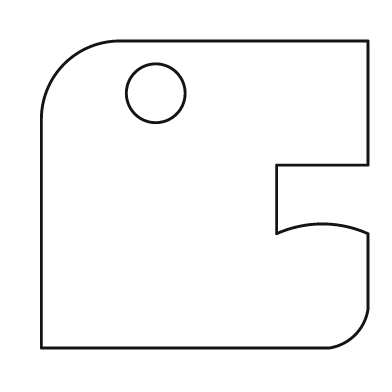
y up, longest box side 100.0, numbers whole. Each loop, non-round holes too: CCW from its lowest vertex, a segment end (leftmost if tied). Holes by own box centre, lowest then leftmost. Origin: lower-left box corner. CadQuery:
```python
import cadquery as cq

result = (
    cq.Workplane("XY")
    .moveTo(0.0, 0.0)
    .lineTo(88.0, 0.0)
    .threePointArc((96.0, 4.0), (100.0, 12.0))
    .lineTo(100.0, 35.0)
    .threePointArc((86.0, 38.0), (72.0, 35.0))
    .lineTo(72.0, 56.0)
    .lineTo(100.0, 56.0)
    .lineTo(100.0, 94.0)
    .lineTo(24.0, 94.0)
    .threePointArc((7.0, 87.0), (0.0, 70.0))
    .close()
    .moveTo(35.0, 78.0)
    .circle(9.0)
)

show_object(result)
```